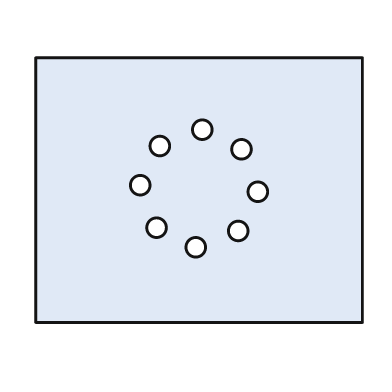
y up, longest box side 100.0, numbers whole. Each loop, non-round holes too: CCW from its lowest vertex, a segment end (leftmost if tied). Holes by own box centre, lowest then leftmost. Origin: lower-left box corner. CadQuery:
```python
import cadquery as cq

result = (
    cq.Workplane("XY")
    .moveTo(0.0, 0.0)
    .lineTo(100.0, 0.0)
    .lineTo(100.0, 81.0)
    .lineTo(0.0, 81.0)
    .close()
    .moveTo(49.0, 23.0)
    .circle(3.0)
    .moveTo(62.0, 28.0)
    .circle(3.0)
    .moveTo(37.0, 29.0)
    .circle(3.0)
    .moveTo(68.0, 40.0)
    .circle(3.0)
    .moveTo(32.0, 42.0)
    .circle(3.0)
    .moveTo(63.0, 53.0)
    .circle(3.0)
    .moveTo(38.0, 54.0)
    .circle(3.0)
    .moveTo(51.0, 59.0)
    .circle(3.0)
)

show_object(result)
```